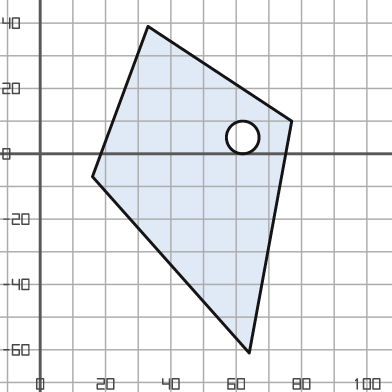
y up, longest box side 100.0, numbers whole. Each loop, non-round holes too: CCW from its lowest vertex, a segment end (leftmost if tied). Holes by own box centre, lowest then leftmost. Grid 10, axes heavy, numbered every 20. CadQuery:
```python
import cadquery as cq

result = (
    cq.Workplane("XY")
    .moveTo(64.0, -61.0)
    .lineTo(77.0, 10.0)
    .lineTo(33.0, 39.0)
    .lineTo(16.0, -7.0)
    .close()
    .moveTo(62.0, 5.0)
    .circle(5.0)
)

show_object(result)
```